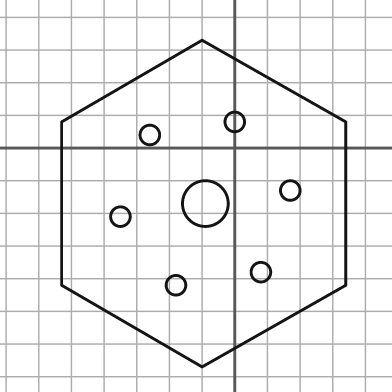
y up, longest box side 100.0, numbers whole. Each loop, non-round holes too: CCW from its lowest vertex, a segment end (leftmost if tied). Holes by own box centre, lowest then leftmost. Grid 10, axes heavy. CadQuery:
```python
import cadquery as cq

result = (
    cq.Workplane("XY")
    .moveTo(-10.0, -67.0)
    .lineTo(34.0, -42.0)
    .lineTo(34.0, 8.0)
    .lineTo(-10.0, 33.0)
    .lineTo(-53.0, 8.0)
    .lineTo(-53.0, -42.0)
    .close()
    .moveTo(-18.0, -42.0)
    .circle(3.0)
    .moveTo(8.0, -38.0)
    .circle(3.0)
    .moveTo(-35.0, -21.0)
    .circle(3.0)
    .moveTo(-9.0, -17.0)
    .circle(7.0)
    .moveTo(17.0, -13.0)
    .circle(3.0)
    .moveTo(-26.0, 4.0)
    .circle(3.0)
    .moveTo(0.0, 8.0)
    .circle(3.0)
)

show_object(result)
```